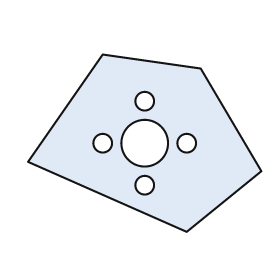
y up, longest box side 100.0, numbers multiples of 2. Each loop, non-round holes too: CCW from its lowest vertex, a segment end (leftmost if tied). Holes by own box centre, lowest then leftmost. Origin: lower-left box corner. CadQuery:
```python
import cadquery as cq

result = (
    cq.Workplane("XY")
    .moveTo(68.0, 0.0)
    .lineTo(100.0, 26.0)
    .lineTo(74.0, 70.0)
    .lineTo(32.0, 76.0)
    .lineTo(0.0, 30.0)
    .close()
    .moveTo(50.0, 20.0)
    .circle(4.0)
    .moveTo(32.0, 38.0)
    .circle(4.0)
    .moveTo(50.0, 38.0)
    .circle(10.0)
    .moveTo(68.0, 38.0)
    .circle(4.0)
    .moveTo(50.0, 56.0)
    .circle(4.0)
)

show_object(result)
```